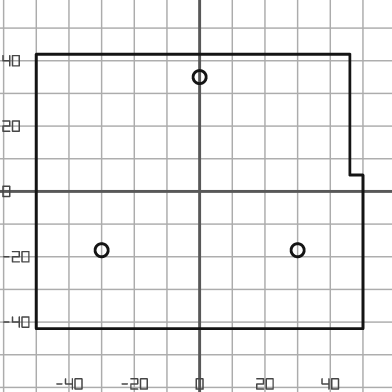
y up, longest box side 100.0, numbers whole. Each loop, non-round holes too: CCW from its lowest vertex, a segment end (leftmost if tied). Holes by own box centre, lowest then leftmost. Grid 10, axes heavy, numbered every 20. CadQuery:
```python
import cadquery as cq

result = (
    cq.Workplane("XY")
    .moveTo(-50.0, -42.0)
    .lineTo(50.0, -42.0)
    .lineTo(50.0, 5.0)
    .lineTo(46.0, 5.0)
    .lineTo(46.0, 42.0)
    .lineTo(-50.0, 42.0)
    .close()
    .moveTo(-30.0, -18.0)
    .circle(2.0)
    .moveTo(30.0, -18.0)
    .circle(2.0)
    .moveTo(0.0, 35.0)
    .circle(2.0)
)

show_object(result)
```